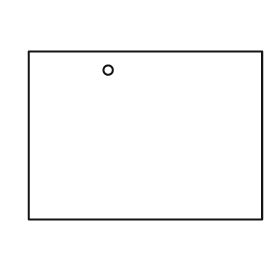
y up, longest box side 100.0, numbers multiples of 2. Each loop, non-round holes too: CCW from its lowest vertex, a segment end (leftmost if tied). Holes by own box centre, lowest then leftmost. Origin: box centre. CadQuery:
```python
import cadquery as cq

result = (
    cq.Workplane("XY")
    .moveTo(-50.0, -36.0)
    .lineTo(50.0, -36.0)
    .lineTo(50.0, 36.0)
    .lineTo(-50.0, 36.0)
    .close()
    .moveTo(-16.0, 28.0)
    .circle(2.0)
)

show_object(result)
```